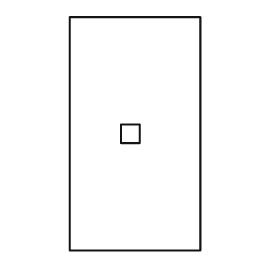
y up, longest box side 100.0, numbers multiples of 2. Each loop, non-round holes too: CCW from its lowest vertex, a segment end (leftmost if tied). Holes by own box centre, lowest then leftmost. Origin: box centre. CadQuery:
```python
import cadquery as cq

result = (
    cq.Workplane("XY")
    .moveTo(-28.0, -50.0)
    .lineTo(28.0, -50.0)
    .lineTo(28.0, 50.0)
    .lineTo(-28.0, 50.0)
    .close()
    .moveTo(-6.0, -4.0)
    .lineTo(2.0, -4.0)
    .lineTo(2.0, 4.0)
    .lineTo(-6.0, 4.0)
    .close()
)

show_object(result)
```